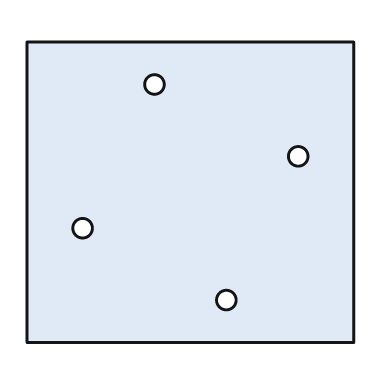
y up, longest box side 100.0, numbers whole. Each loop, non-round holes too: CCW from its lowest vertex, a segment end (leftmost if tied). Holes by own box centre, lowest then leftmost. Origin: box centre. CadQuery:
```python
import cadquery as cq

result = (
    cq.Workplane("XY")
    .moveTo(-50.0, -46.0)
    .lineTo(50.0, -46.0)
    .lineTo(50.0, 46.0)
    .lineTo(-50.0, 46.0)
    .close()
    .moveTo(11.0, -33.0)
    .circle(3.0)
    .moveTo(-33.0, -11.0)
    .circle(3.0)
    .moveTo(33.0, 11.0)
    .circle(3.0)
    .moveTo(-11.0, 33.0)
    .circle(3.0)
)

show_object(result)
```